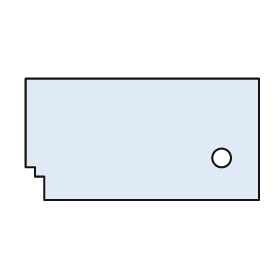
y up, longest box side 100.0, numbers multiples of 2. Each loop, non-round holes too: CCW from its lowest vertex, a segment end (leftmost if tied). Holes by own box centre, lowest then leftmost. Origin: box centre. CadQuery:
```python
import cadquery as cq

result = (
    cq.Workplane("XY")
    .moveTo(-42.0, -26.0)
    .lineTo(50.0, -26.0)
    .lineTo(50.0, 26.0)
    .lineTo(-50.0, 26.0)
    .lineTo(-50.0, -12.0)
    .lineTo(-46.0, -12.0)
    .lineTo(-46.0, -16.0)
    .lineTo(-42.0, -16.0)
    .close()
    .moveTo(34.0, -8.0)
    .circle(4.0)
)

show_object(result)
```